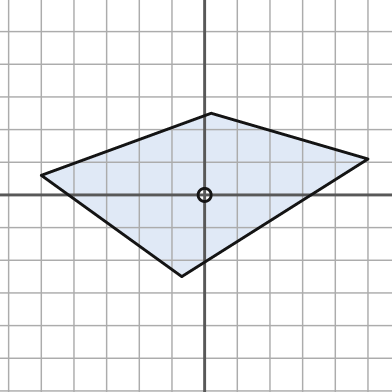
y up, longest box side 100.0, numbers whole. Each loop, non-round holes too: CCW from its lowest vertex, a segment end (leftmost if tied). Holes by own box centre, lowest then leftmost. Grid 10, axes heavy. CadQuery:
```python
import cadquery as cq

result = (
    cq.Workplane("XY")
    .moveTo(-7.0, -25.0)
    .lineTo(50.0, 11.0)
    .lineTo(2.0, 25.0)
    .lineTo(-50.0, 6.0)
    .close()
    .moveTo(0.0, 0.0)
    .circle(2.0)
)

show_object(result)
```